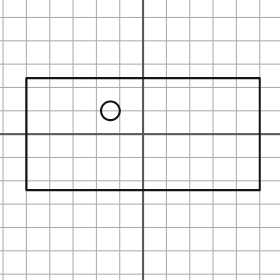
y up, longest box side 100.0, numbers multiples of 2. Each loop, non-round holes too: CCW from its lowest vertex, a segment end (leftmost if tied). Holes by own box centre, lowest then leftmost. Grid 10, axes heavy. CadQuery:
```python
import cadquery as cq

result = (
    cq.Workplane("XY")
    .moveTo(-50.0, -24.0)
    .lineTo(50.0, -24.0)
    .lineTo(50.0, 24.0)
    .lineTo(-50.0, 24.0)
    .close()
    .moveTo(-14.0, 10.0)
    .circle(4.0)
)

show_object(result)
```